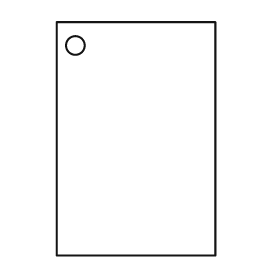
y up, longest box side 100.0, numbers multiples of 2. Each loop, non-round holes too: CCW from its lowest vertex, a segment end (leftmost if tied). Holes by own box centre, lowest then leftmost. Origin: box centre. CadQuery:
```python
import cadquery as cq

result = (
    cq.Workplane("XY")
    .moveTo(-34.0, -50.0)
    .lineTo(34.0, -50.0)
    .lineTo(34.0, 50.0)
    .lineTo(-34.0, 50.0)
    .close()
    .moveTo(-26.0, 40.0)
    .circle(4.0)
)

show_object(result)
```